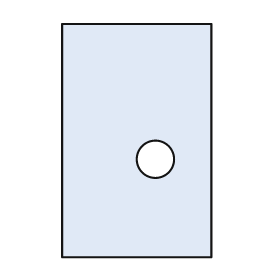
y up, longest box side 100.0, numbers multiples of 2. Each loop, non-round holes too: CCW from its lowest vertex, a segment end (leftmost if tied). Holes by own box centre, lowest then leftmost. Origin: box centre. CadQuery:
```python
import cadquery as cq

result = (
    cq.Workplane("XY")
    .moveTo(-32.0, -50.0)
    .lineTo(32.0, -50.0)
    .lineTo(32.0, 50.0)
    .lineTo(-32.0, 50.0)
    .close()
    .moveTo(8.0, -8.0)
    .circle(8.0)
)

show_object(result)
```